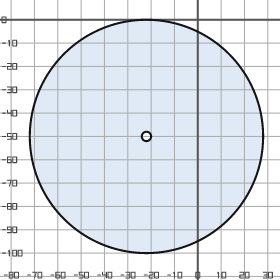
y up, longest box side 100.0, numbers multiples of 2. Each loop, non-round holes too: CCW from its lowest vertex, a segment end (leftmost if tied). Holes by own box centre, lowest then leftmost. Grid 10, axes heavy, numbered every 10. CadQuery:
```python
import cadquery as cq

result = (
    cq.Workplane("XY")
    .moveTo(-22.0, -50.0)
    .circle(50.0)
    .moveTo(-22.0, -50.0)
    .circle(2.0)
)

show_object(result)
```